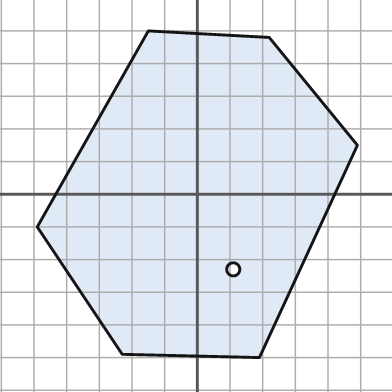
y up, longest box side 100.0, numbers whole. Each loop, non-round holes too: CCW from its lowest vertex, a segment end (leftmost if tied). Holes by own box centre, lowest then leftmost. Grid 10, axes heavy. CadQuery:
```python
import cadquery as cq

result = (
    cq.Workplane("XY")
    .moveTo(19.0, -50.0)
    .lineTo(49.0, 15.0)
    .lineTo(22.0, 48.0)
    .lineTo(-15.0, 50.0)
    .lineTo(-49.0, -10.0)
    .lineTo(-23.0, -49.0)
    .close()
    .moveTo(11.0, -23.0)
    .circle(2.0)
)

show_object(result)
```